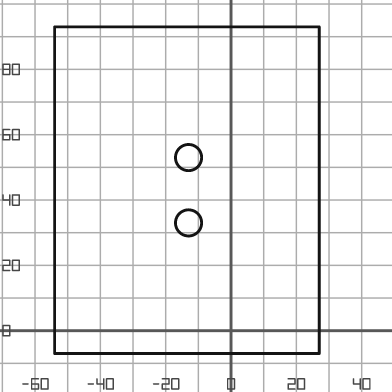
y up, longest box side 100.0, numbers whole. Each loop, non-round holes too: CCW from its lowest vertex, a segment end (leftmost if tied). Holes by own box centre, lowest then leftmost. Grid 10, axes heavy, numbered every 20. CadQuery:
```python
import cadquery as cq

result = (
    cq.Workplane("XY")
    .moveTo(-54.0, -7.0)
    .lineTo(27.0, -7.0)
    .lineTo(27.0, 93.0)
    .lineTo(-54.0, 93.0)
    .close()
    .moveTo(-13.0, 33.0)
    .circle(4.0)
    .moveTo(-13.0, 53.0)
    .circle(4.0)
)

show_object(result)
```